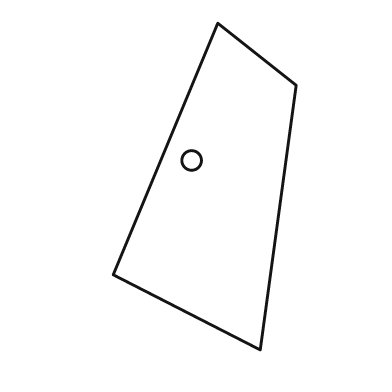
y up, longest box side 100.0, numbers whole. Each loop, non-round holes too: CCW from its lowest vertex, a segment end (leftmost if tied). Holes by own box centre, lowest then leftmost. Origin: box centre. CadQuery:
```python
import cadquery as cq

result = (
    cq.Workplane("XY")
    .moveTo(17.0, -50.0)
    .lineTo(28.0, 31.0)
    .lineTo(4.0, 50.0)
    .lineTo(-28.0, -27.0)
    .close()
    .moveTo(-4.0, 8.0)
    .circle(3.0)
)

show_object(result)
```